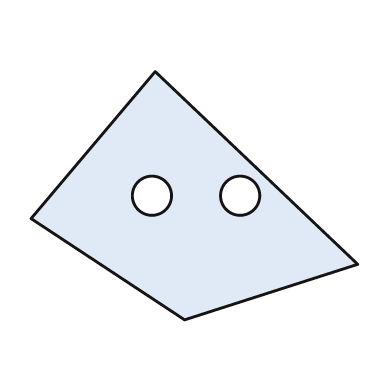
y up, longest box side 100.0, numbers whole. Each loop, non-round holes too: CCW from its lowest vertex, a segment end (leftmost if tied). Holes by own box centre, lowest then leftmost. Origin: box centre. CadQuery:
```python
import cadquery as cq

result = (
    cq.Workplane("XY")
    .moveTo(-3.0, -38.0)
    .lineTo(50.0, -21.0)
    .lineTo(-12.0, 38.0)
    .lineTo(-50.0, -7.0)
    .close()
    .moveTo(-13.0, 0.0)
    .circle(6.0)
    .moveTo(14.0, 0.0)
    .circle(6.0)
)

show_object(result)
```